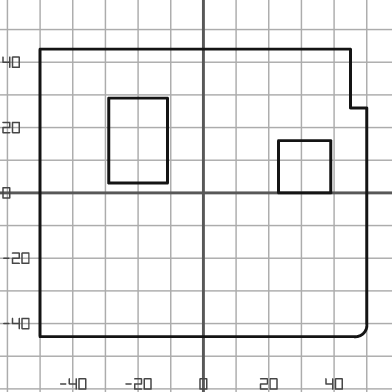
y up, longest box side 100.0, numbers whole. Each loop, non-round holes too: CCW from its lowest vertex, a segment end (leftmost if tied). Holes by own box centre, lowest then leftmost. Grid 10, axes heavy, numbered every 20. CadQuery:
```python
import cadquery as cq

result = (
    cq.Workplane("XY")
    .moveTo(-50.0, -44.0)
    .lineTo(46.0, -44.0)
    .threePointArc((49.0, -43.0), (50.0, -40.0))
    .lineTo(50.0, 26.0)
    .lineTo(45.0, 26.0)
    .lineTo(45.0, 44.0)
    .lineTo(-50.0, 44.0)
    .close()
    .moveTo(23.0, 0.0)
    .lineTo(39.0, 0.0)
    .lineTo(39.0, 16.0)
    .lineTo(23.0, 16.0)
    .close()
    .moveTo(-29.0, 3.0)
    .lineTo(-11.0, 3.0)
    .lineTo(-11.0, 29.0)
    .lineTo(-29.0, 29.0)
    .close()
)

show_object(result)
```